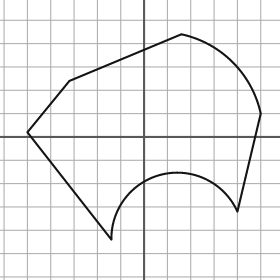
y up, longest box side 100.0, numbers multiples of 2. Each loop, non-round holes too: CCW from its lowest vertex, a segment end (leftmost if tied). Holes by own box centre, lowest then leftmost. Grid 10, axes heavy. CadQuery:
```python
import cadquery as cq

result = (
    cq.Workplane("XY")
    .moveTo(-14.0, -44.0)
    .threePointArc((8.0, -16.0), (40.0, -32.0))
    .lineTo(50.0, 10.0)
    .threePointArc((38.0, 32.0), (16.0, 44.0))
    .lineTo(-32.0, 24.0)
    .lineTo(-50.0, 2.0)
    .close()
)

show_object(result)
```